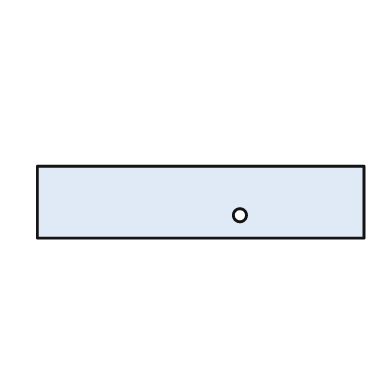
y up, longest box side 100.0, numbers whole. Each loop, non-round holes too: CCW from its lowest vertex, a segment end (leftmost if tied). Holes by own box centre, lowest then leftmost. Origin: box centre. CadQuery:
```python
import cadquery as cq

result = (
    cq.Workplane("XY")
    .moveTo(-50.0, -11.0)
    .lineTo(50.0, -11.0)
    .lineTo(50.0, 11.0)
    .lineTo(-50.0, 11.0)
    .close()
    .moveTo(12.0, -4.0)
    .circle(2.0)
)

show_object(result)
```